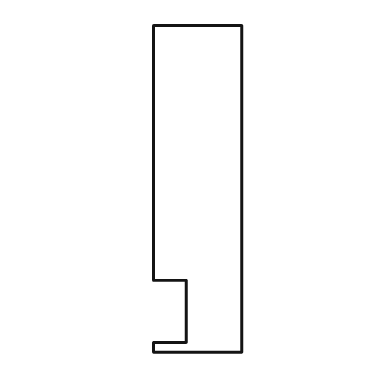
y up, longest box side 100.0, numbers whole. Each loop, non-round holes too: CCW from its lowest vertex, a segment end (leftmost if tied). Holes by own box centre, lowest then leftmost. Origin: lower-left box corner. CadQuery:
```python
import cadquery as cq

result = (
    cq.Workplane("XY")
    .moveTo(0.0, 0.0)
    .lineTo(27.0, 0.0)
    .lineTo(27.0, 100.0)
    .lineTo(0.0, 100.0)
    .lineTo(0.0, 22.0)
    .lineTo(10.0, 22.0)
    .lineTo(10.0, 3.0)
    .lineTo(0.0, 3.0)
    .close()
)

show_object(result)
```